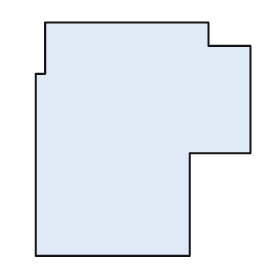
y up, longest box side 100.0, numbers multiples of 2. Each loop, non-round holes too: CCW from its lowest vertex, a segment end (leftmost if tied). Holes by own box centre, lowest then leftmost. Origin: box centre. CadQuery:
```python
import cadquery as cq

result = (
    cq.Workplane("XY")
    .moveTo(-46.0, -50.0)
    .lineTo(20.0, -50.0)
    .lineTo(20.0, -6.0)
    .lineTo(46.0, -6.0)
    .lineTo(46.0, 40.0)
    .lineTo(28.0, 40.0)
    .lineTo(28.0, 50.0)
    .lineTo(-42.0, 50.0)
    .lineTo(-42.0, 28.0)
    .lineTo(-46.0, 28.0)
    .close()
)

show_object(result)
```